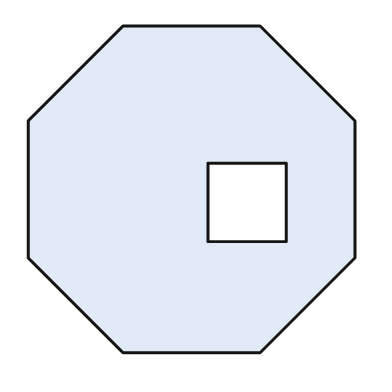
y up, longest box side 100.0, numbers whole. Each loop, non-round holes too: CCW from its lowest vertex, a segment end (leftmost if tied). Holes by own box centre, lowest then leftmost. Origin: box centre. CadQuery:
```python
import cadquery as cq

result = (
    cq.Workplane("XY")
    .moveTo(-21.0, -50.0)
    .lineTo(21.0, -50.0)
    .lineTo(50.0, -21.0)
    .lineTo(50.0, 21.0)
    .lineTo(21.0, 50.0)
    .lineTo(-21.0, 50.0)
    .lineTo(-50.0, 21.0)
    .lineTo(-50.0, -21.0)
    .close()
    .moveTo(5.0, -16.0)
    .lineTo(29.0, -16.0)
    .lineTo(29.0, 8.0)
    .lineTo(5.0, 8.0)
    .close()
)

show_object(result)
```